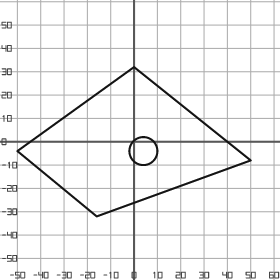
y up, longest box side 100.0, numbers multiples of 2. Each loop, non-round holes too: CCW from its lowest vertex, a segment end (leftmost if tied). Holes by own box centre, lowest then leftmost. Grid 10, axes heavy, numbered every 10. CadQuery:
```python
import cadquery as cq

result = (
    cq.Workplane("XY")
    .moveTo(-16.0, -32.0)
    .lineTo(50.0, -8.0)
    .lineTo(0.0, 32.0)
    .lineTo(-50.0, -4.0)
    .close()
    .moveTo(4.0, -4.0)
    .circle(6.0)
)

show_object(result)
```